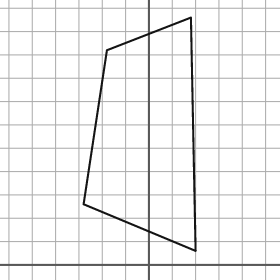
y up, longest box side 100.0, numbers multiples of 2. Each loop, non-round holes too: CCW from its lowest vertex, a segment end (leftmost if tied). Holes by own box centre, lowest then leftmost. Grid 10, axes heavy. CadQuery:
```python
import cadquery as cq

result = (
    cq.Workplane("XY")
    .moveTo(20.0, 6.0)
    .lineTo(18.0, 106.0)
    .lineTo(-18.0, 92.0)
    .lineTo(-28.0, 26.0)
    .close()
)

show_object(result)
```